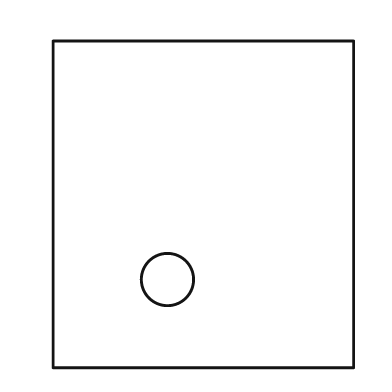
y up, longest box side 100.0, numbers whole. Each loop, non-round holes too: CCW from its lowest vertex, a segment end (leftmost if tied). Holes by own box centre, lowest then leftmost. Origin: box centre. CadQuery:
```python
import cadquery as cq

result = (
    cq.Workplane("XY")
    .moveTo(-46.0, -50.0)
    .lineTo(46.0, -50.0)
    .lineTo(46.0, 50.0)
    .lineTo(-46.0, 50.0)
    .close()
    .moveTo(-11.0, -23.0)
    .circle(8.0)
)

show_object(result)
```